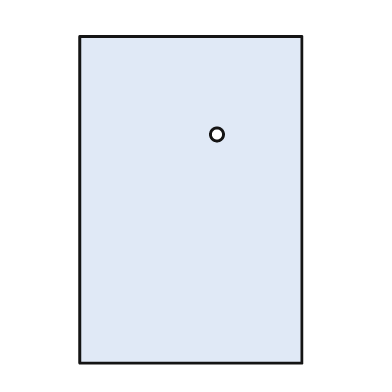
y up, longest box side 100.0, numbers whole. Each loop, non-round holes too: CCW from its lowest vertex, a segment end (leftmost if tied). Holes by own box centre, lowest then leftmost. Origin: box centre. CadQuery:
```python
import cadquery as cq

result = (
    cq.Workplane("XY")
    .moveTo(-34.0, -50.0)
    .lineTo(34.0, -50.0)
    .lineTo(34.0, 50.0)
    .lineTo(-34.0, 50.0)
    .close()
    .moveTo(8.0, 20.0)
    .circle(2.0)
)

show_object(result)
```